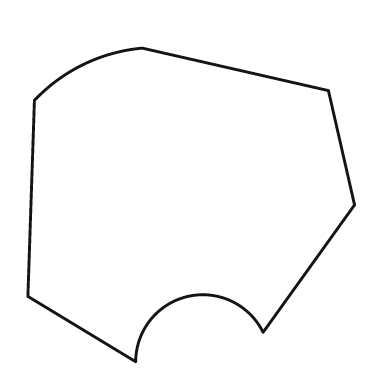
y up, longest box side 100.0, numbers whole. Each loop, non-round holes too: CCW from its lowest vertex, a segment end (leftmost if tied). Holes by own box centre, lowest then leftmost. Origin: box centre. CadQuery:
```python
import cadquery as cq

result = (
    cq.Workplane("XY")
    .moveTo(-17.0, -48.0)
    .threePointArc((-1.0, -28.0), (22.0, -39.0))
    .lineTo(50.0, 0.0)
    .lineTo(42.0, 35.0)
    .lineTo(-15.0, 48.0)
    .threePointArc((-33.0, 43.0), (-48.0, 32.0))
    .lineTo(-50.0, -28.0)
    .close()
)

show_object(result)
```